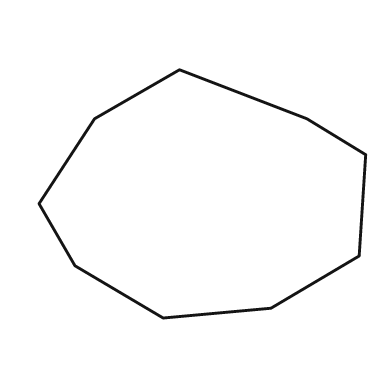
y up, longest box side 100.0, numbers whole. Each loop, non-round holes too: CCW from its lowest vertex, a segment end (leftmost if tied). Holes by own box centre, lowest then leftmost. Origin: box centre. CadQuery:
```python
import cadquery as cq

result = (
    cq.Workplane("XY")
    .moveTo(-12.0, -38.0)
    .lineTo(21.0, -35.0)
    .lineTo(48.0, -19.0)
    .lineTo(50.0, 12.0)
    .lineTo(32.0, 23.0)
    .lineTo(-7.0, 38.0)
    .lineTo(-33.0, 23.0)
    .lineTo(-50.0, -3.0)
    .lineTo(-39.0, -22.0)
    .close()
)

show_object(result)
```